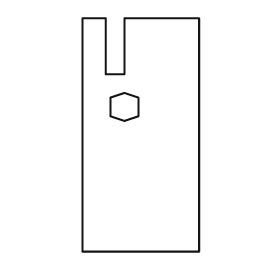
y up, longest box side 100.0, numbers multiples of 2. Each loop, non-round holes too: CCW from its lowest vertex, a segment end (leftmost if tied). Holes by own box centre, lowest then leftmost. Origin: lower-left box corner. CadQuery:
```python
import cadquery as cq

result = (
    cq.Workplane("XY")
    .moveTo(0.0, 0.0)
    .lineTo(50.0, 0.0)
    .lineTo(50.0, 100.0)
    .lineTo(18.0, 100.0)
    .lineTo(18.0, 76.0)
    .lineTo(10.0, 76.0)
    .lineTo(10.0, 100.0)
    .lineTo(0.0, 100.0)
    .close()
    .moveTo(18.0, 56.0)
    .lineTo(24.0, 58.0)
    .lineTo(24.0, 66.0)
    .lineTo(18.0, 68.0)
    .lineTo(12.0, 66.0)
    .lineTo(12.0, 58.0)
    .close()
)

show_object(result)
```